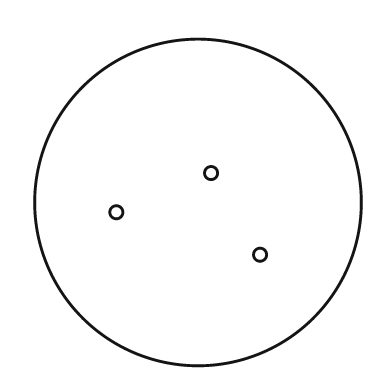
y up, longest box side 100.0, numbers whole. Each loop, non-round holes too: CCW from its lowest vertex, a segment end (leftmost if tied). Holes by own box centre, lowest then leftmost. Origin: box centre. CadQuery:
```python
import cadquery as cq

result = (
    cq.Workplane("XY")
    .moveTo(0.0, 0.0)
    .circle(50.0)
    .moveTo(19.0, -16.0)
    .circle(2.0)
    .moveTo(-25.0, -3.0)
    .circle(2.0)
    .moveTo(4.0, 9.0)
    .circle(2.0)
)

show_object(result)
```